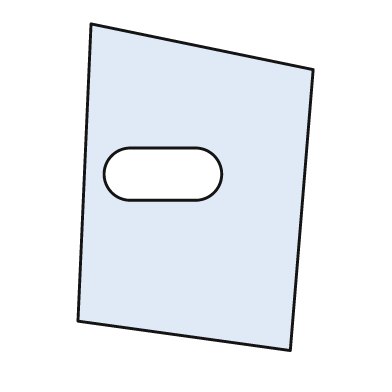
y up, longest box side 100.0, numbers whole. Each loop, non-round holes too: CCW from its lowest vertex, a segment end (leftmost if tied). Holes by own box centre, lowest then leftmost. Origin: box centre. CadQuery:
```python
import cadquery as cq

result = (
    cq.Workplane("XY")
    .moveTo(29.0, -50.0)
    .lineTo(36.0, 36.0)
    .lineTo(-32.0, 50.0)
    .lineTo(-36.0, -41.0)
    .close()
    .moveTo(-20.0, -4.0)
    .lineTo(0.0, -4.0)
    .threePointArc((8.0, 4.0), (0.0, 12.0))
    .lineTo(-20.0, 12.0)
    .threePointArc((-28.0, 4.0), (-20.0, -4.0))
    .close()
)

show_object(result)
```